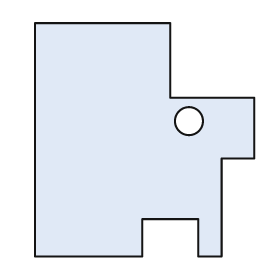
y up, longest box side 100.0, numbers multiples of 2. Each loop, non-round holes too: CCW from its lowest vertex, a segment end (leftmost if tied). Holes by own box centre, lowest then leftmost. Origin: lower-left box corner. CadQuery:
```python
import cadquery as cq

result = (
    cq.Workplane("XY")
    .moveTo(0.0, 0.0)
    .lineTo(46.0, 0.0)
    .lineTo(46.0, 16.0)
    .lineTo(70.0, 16.0)
    .lineTo(70.0, 0.0)
    .lineTo(80.0, 0.0)
    .lineTo(80.0, 42.0)
    .lineTo(94.0, 42.0)
    .lineTo(94.0, 68.0)
    .lineTo(58.0, 68.0)
    .lineTo(58.0, 100.0)
    .lineTo(0.0, 100.0)
    .close()
    .moveTo(66.0, 58.0)
    .circle(6.0)
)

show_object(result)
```